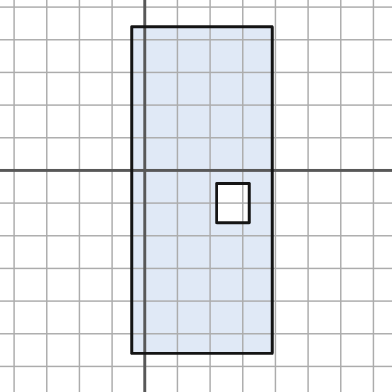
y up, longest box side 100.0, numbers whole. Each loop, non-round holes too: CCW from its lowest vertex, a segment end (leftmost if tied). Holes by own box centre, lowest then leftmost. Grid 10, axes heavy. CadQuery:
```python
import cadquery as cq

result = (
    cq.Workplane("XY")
    .moveTo(-4.0, -56.0)
    .lineTo(39.0, -56.0)
    .lineTo(39.0, 44.0)
    .lineTo(-4.0, 44.0)
    .close()
    .moveTo(22.0, -16.0)
    .lineTo(32.0, -16.0)
    .lineTo(32.0, -4.0)
    .lineTo(22.0, -4.0)
    .close()
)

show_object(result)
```